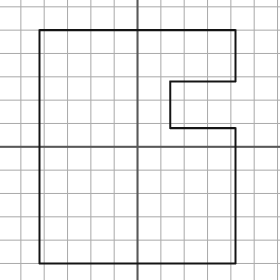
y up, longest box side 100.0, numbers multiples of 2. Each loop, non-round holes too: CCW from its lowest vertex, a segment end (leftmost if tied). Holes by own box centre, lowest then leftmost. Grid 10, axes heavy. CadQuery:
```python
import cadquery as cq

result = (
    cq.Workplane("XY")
    .moveTo(-42.0, -50.0)
    .lineTo(42.0, -50.0)
    .lineTo(42.0, 8.0)
    .lineTo(14.0, 8.0)
    .lineTo(14.0, 28.0)
    .lineTo(42.0, 28.0)
    .lineTo(42.0, 50.0)
    .lineTo(-42.0, 50.0)
    .close()
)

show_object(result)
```